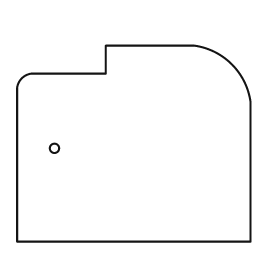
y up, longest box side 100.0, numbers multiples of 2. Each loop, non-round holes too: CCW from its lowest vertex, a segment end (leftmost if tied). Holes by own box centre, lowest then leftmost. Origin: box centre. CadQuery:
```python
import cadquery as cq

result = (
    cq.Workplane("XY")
    .moveTo(-50.0, -42.0)
    .lineTo(50.0, -42.0)
    .lineTo(50.0, 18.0)
    .threePointArc((42.0, 34.0), (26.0, 42.0))
    .lineTo(-12.0, 42.0)
    .lineTo(-12.0, 30.0)
    .lineTo(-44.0, 30.0)
    .threePointArc((-48.0, 28.0), (-50.0, 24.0))
    .close()
    .moveTo(-34.0, -2.0)
    .circle(2.0)
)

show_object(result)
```